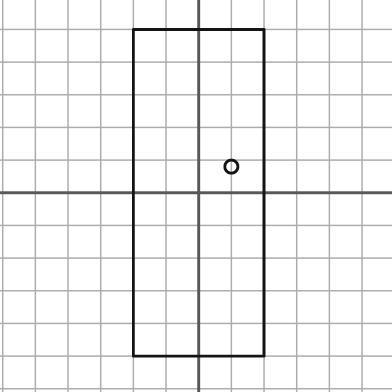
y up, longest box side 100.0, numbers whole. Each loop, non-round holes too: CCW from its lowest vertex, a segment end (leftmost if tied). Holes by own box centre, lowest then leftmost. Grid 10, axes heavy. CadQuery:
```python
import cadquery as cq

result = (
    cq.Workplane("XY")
    .moveTo(-20.0, -50.0)
    .lineTo(20.0, -50.0)
    .lineTo(20.0, 50.0)
    .lineTo(-20.0, 50.0)
    .close()
    .moveTo(10.0, 8.0)
    .circle(2.0)
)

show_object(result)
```